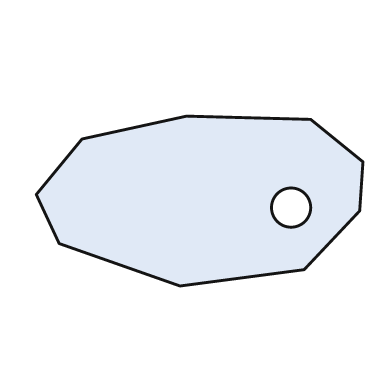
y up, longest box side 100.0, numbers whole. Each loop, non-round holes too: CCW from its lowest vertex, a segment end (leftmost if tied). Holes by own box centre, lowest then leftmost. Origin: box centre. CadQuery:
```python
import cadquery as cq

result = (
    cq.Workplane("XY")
    .moveTo(-6.0, -26.0)
    .lineTo(32.0, -21.0)
    .lineTo(49.0, -3.0)
    .lineTo(50.0, 12.0)
    .lineTo(34.0, 25.0)
    .lineTo(-4.0, 26.0)
    .lineTo(-36.0, 19.0)
    .lineTo(-50.0, 2.0)
    .lineTo(-43.0, -13.0)
    .close()
    .moveTo(28.0, -2.0)
    .circle(6.0)
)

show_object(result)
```